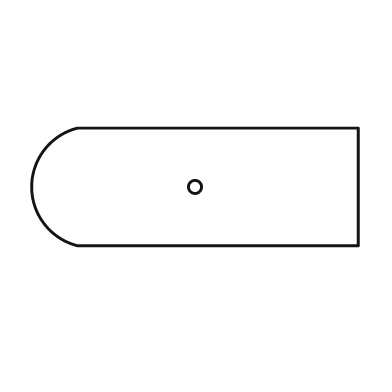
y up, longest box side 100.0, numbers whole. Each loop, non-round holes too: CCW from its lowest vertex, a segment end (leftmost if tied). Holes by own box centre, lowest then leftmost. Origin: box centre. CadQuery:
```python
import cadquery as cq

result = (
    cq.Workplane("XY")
    .moveTo(-36.0, -18.0)
    .lineTo(50.0, -18.0)
    .lineTo(50.0, 18.0)
    .lineTo(-36.0, 18.0)
    .threePointArc((-50.0, 0.0), (-36.0, -18.0))
    .close()
    .moveTo(0.0, 0.0)
    .circle(2.0)
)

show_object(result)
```